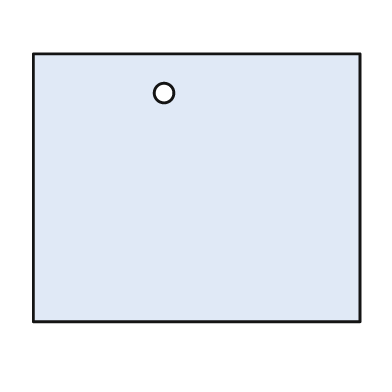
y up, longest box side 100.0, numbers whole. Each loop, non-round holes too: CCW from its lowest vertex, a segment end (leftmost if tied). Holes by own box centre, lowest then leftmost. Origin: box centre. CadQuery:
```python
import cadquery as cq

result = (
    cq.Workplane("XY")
    .moveTo(-50.0, -41.0)
    .lineTo(50.0, -41.0)
    .lineTo(50.0, 41.0)
    .lineTo(-50.0, 41.0)
    .close()
    .moveTo(-10.0, 29.0)
    .circle(3.0)
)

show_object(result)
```